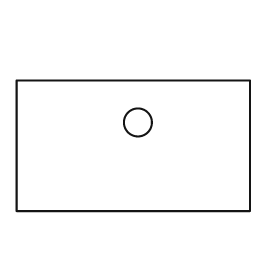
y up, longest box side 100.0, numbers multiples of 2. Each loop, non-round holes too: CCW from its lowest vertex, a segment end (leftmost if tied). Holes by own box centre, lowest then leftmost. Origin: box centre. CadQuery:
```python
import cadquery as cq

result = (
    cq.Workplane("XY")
    .moveTo(-50.0, -28.0)
    .lineTo(50.0, -28.0)
    .lineTo(50.0, 28.0)
    .lineTo(-50.0, 28.0)
    .close()
    .moveTo(2.0, 10.0)
    .circle(6.0)
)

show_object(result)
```